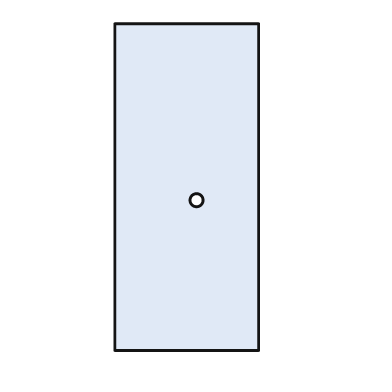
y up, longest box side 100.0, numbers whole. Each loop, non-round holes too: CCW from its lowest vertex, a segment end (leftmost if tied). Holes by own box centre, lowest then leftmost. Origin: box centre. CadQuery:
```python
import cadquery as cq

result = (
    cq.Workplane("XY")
    .moveTo(-22.0, -50.0)
    .lineTo(22.0, -50.0)
    .lineTo(22.0, 50.0)
    .lineTo(-22.0, 50.0)
    .close()
    .moveTo(3.0, -4.0)
    .circle(2.0)
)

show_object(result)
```